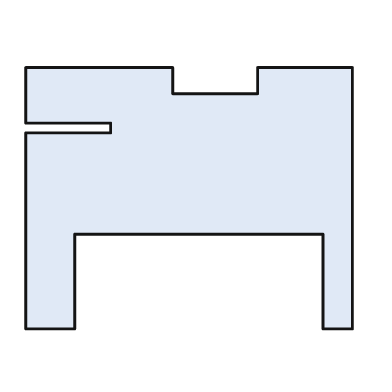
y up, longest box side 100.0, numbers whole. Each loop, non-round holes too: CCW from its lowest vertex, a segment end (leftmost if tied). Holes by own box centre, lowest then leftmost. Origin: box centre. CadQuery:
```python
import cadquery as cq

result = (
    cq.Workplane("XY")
    .moveTo(-50.0, -40.0)
    .lineTo(-35.0, -40.0)
    .lineTo(-35.0, -11.0)
    .lineTo(41.0, -11.0)
    .lineTo(41.0, -40.0)
    .lineTo(50.0, -40.0)
    .lineTo(50.0, 40.0)
    .lineTo(21.0, 40.0)
    .lineTo(21.0, 32.0)
    .lineTo(-5.0, 32.0)
    .lineTo(-5.0, 40.0)
    .lineTo(-50.0, 40.0)
    .lineTo(-50.0, 23.0)
    .lineTo(-24.0, 23.0)
    .lineTo(-24.0, 20.0)
    .lineTo(-50.0, 20.0)
    .close()
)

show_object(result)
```